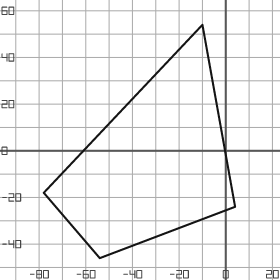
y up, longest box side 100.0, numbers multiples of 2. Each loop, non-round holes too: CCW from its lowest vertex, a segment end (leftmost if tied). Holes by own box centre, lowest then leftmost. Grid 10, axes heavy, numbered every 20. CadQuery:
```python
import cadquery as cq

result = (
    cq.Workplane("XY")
    .moveTo(-54.0, -46.0)
    .lineTo(4.0, -24.0)
    .lineTo(-10.0, 54.0)
    .lineTo(-78.0, -18.0)
    .close()
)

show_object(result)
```